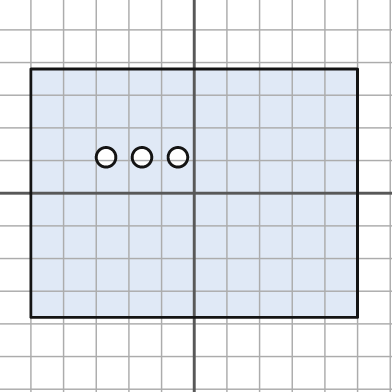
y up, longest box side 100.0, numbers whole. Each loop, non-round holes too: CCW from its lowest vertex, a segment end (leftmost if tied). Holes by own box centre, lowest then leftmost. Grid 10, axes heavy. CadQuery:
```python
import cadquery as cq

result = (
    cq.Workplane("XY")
    .moveTo(-50.0, -38.0)
    .lineTo(50.0, -38.0)
    .lineTo(50.0, 38.0)
    .lineTo(-50.0, 38.0)
    .close()
    .moveTo(-27.0, 11.0)
    .circle(3.0)
    .moveTo(-16.0, 11.0)
    .circle(3.0)
    .moveTo(-5.0, 11.0)
    .circle(3.0)
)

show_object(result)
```